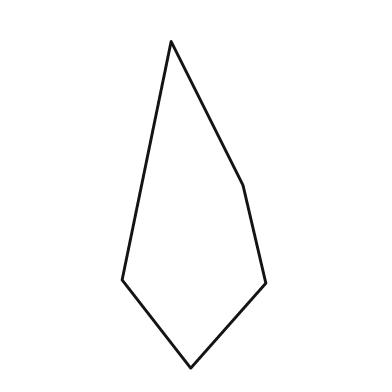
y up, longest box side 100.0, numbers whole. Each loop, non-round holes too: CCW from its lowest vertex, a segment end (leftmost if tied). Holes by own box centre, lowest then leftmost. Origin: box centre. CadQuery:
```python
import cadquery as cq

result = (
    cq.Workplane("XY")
    .moveTo(-1.0, -50.0)
    .lineTo(22.0, -24.0)
    .lineTo(15.0, 6.0)
    .lineTo(-7.0, 50.0)
    .lineTo(-22.0, -23.0)
    .close()
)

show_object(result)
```